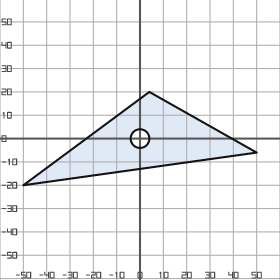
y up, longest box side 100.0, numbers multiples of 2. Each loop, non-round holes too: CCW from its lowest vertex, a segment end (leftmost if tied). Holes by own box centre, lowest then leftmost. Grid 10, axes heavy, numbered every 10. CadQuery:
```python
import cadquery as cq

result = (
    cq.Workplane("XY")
    .moveTo(-50.0, -20.0)
    .lineTo(50.0, -6.0)
    .lineTo(4.0, 20.0)
    .close()
    .moveTo(0.0, 0.0)
    .circle(4.0)
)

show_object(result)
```